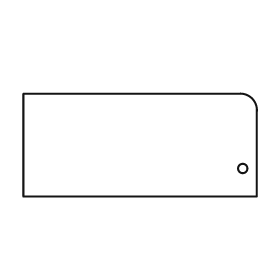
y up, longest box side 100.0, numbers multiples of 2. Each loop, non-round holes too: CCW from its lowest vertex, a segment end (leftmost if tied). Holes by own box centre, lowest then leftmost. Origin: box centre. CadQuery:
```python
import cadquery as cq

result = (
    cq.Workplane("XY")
    .moveTo(-50.0, -22.0)
    .lineTo(50.0, -22.0)
    .lineTo(50.0, 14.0)
    .threePointArc((48.0, 20.0), (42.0, 22.0))
    .lineTo(-50.0, 22.0)
    .close()
    .moveTo(44.0, -10.0)
    .circle(2.0)
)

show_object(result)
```